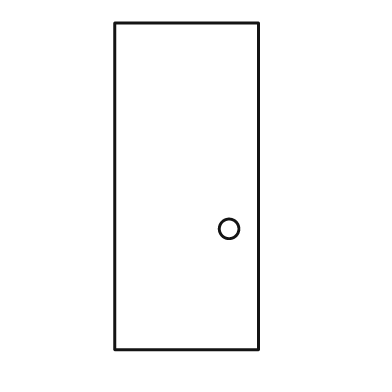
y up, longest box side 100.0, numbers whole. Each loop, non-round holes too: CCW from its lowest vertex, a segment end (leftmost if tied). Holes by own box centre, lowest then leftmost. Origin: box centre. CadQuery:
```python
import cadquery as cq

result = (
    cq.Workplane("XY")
    .moveTo(-22.0, -50.0)
    .lineTo(22.0, -50.0)
    .lineTo(22.0, 50.0)
    .lineTo(-22.0, 50.0)
    .close()
    .moveTo(13.0, -13.0)
    .circle(3.0)
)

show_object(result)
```